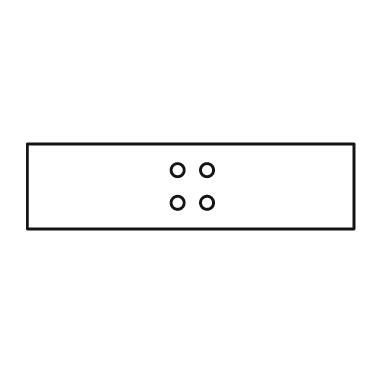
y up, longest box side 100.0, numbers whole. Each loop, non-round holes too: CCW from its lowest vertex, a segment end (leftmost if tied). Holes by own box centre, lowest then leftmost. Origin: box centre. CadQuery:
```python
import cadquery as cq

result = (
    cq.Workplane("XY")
    .moveTo(-50.0, -13.0)
    .lineTo(50.0, -13.0)
    .lineTo(50.0, 13.0)
    .lineTo(-50.0, 13.0)
    .close()
    .moveTo(-4.0, -5.0)
    .circle(2.0)
    .moveTo(5.0, -5.0)
    .circle(2.0)
    .moveTo(-4.0, 5.0)
    .circle(2.0)
    .moveTo(5.0, 5.0)
    .circle(2.0)
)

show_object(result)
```